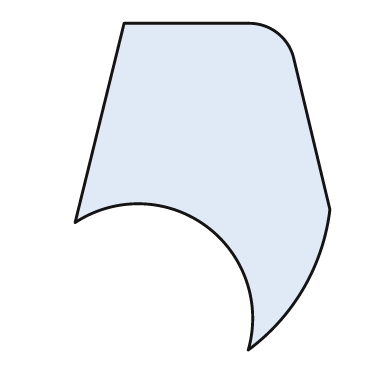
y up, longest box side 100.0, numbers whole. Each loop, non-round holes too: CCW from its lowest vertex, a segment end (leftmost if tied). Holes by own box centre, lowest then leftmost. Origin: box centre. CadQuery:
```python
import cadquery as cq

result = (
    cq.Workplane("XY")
    .moveTo(14.0, -50.0)
    .threePointArc((31.0, -31.0), (39.0, -7.0))
    .lineTo(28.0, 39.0)
    .threePointArc((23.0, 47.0), (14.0, 50.0))
    .lineTo(-24.0, 50.0)
    .lineTo(-39.0, -11.0)
    .threePointArc((1.0, -12.0), (14.0, -50.0))
    .close()
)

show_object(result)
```